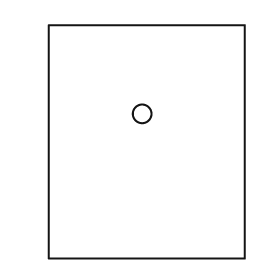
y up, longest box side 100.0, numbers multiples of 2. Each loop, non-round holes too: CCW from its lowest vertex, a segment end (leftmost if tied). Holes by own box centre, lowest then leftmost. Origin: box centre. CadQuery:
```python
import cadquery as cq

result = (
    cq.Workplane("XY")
    .moveTo(-42.0, -50.0)
    .lineTo(42.0, -50.0)
    .lineTo(42.0, 50.0)
    .lineTo(-42.0, 50.0)
    .close()
    .moveTo(-2.0, 12.0)
    .circle(4.0)
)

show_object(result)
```